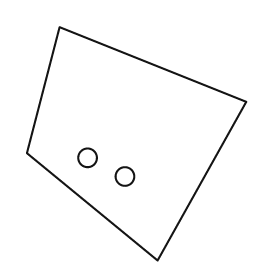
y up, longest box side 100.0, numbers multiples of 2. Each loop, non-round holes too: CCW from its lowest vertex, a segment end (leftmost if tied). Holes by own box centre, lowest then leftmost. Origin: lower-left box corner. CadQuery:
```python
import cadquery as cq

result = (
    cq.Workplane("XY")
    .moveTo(56.0, 0.0)
    .lineTo(94.0, 68.0)
    .lineTo(14.0, 100.0)
    .lineTo(0.0, 46.0)
    .close()
    .moveTo(42.0, 36.0)
    .circle(4.0)
    .moveTo(26.0, 44.0)
    .circle(4.0)
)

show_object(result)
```